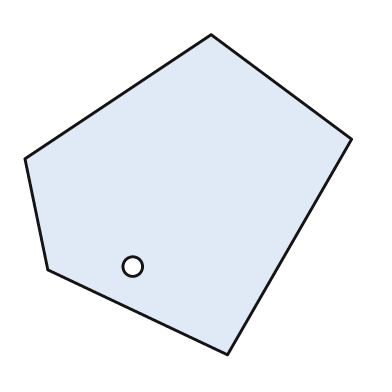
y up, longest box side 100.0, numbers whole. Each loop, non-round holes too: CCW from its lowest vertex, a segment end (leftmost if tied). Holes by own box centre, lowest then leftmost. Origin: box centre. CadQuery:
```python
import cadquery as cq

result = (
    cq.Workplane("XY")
    .moveTo(12.0, -49.0)
    .lineTo(50.0, 17.0)
    .lineTo(7.0, 49.0)
    .lineTo(-50.0, 11.0)
    .lineTo(-43.0, -23.0)
    .close()
    .moveTo(-17.0, -22.0)
    .circle(3.0)
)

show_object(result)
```